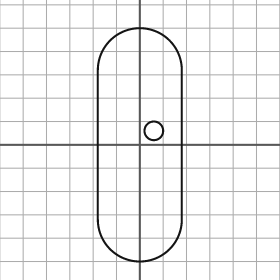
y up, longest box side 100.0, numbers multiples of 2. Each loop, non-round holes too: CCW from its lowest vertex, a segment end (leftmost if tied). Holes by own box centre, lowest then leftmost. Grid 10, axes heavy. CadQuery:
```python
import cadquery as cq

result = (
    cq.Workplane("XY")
    .moveTo(-18.0, -32.0)
    .threePointArc((0.0, -50.0), (18.0, -32.0))
    .lineTo(18.0, 32.0)
    .threePointArc((0.0, 50.0), (-18.0, 32.0))
    .close()
    .moveTo(6.0, 6.0)
    .circle(4.0)
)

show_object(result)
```